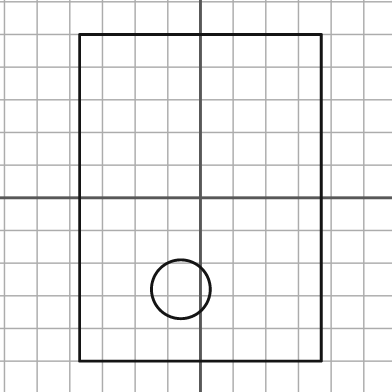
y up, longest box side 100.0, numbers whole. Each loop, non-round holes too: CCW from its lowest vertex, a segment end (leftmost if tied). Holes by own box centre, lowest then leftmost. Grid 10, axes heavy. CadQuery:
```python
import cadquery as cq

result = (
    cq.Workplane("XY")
    .moveTo(-37.0, -50.0)
    .lineTo(37.0, -50.0)
    .lineTo(37.0, 50.0)
    .lineTo(-37.0, 50.0)
    .close()
    .moveTo(-6.0, -28.0)
    .circle(9.0)
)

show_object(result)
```